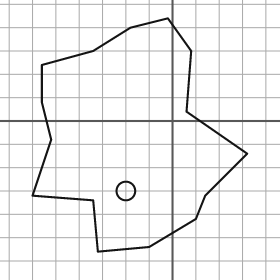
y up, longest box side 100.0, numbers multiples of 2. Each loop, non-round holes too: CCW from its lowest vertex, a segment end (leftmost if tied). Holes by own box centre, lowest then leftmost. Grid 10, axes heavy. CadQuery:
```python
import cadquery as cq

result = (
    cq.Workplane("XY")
    .moveTo(-32.0, -56.0)
    .lineTo(-10.0, -54.0)
    .lineTo(10.0, -42.0)
    .lineTo(14.0, -32.0)
    .lineTo(32.0, -14.0)
    .lineTo(6.0, 4.0)
    .lineTo(8.0, 30.0)
    .lineTo(-2.0, 44.0)
    .lineTo(-18.0, 40.0)
    .lineTo(-34.0, 30.0)
    .lineTo(-56.0, 24.0)
    .lineTo(-56.0, 8.0)
    .lineTo(-52.0, -8.0)
    .lineTo(-60.0, -32.0)
    .lineTo(-34.0, -34.0)
    .close()
    .moveTo(-20.0, -30.0)
    .circle(4.0)
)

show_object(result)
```